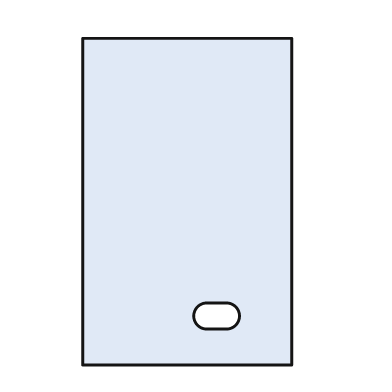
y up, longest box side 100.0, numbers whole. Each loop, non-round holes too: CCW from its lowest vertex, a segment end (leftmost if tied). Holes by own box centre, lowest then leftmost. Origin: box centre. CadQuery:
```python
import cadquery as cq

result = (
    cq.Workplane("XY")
    .moveTo(-32.0, -50.0)
    .lineTo(32.0, -50.0)
    .lineTo(32.0, 50.0)
    .lineTo(-32.0, 50.0)
    .close()
    .moveTo(6.0, -39.0)
    .lineTo(12.0, -39.0)
    .threePointArc((16.0, -35.0), (12.0, -31.0))
    .lineTo(6.0, -31.0)
    .threePointArc((2.0, -35.0), (6.0, -39.0))
    .close()
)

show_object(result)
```